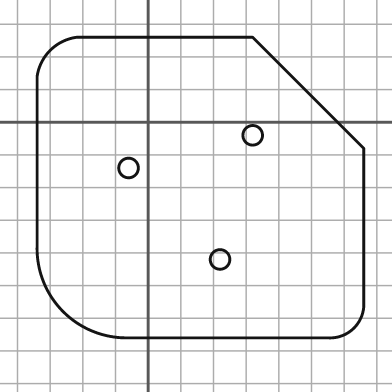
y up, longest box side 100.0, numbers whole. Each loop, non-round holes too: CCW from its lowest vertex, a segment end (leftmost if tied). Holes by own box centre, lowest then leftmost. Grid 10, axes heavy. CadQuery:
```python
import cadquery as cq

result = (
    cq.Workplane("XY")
    .moveTo(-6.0, -66.0)
    .lineTo(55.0, -66.0)
    .threePointArc((63.0, -63.0), (66.0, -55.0))
    .lineTo(66.0, -8.0)
    .lineTo(32.0, 26.0)
    .lineTo(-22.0, 26.0)
    .threePointArc((-30.0, 22.0), (-34.0, 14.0))
    .lineTo(-34.0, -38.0)
    .threePointArc((-26.0, -58.0), (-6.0, -66.0))
    .close()
    .moveTo(22.0, -42.0)
    .circle(3.0)
    .moveTo(-6.0, -14.0)
    .circle(3.0)
    .moveTo(32.0, -4.0)
    .circle(3.0)
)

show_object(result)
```